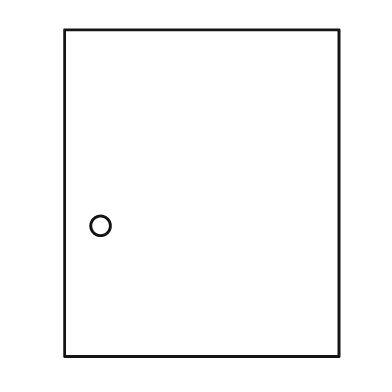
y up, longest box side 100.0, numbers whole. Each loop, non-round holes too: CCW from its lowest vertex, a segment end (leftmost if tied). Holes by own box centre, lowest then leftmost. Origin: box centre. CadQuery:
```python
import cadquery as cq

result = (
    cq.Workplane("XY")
    .moveTo(-42.0, -50.0)
    .lineTo(42.0, -50.0)
    .lineTo(42.0, 50.0)
    .lineTo(-42.0, 50.0)
    .close()
    .moveTo(-31.0, -10.0)
    .circle(3.0)
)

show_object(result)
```